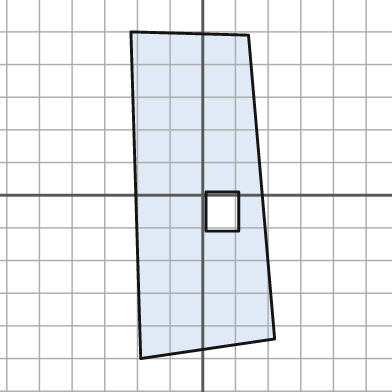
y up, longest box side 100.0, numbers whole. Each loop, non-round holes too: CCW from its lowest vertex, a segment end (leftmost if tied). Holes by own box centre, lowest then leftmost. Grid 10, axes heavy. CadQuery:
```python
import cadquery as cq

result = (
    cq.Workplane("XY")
    .moveTo(-19.0, -50.0)
    .lineTo(22.0, -44.0)
    .lineTo(14.0, 49.0)
    .lineTo(-22.0, 50.0)
    .close()
    .moveTo(1.0, -11.0)
    .lineTo(11.0, -11.0)
    .lineTo(11.0, 1.0)
    .lineTo(1.0, 1.0)
    .close()
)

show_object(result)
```